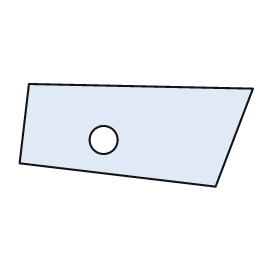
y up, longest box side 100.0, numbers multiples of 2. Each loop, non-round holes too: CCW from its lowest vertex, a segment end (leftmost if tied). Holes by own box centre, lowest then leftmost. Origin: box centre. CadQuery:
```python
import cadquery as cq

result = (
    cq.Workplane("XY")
    .moveTo(34.0, -22.0)
    .lineTo(50.0, 20.0)
    .lineTo(-46.0, 22.0)
    .lineTo(-50.0, -12.0)
    .close()
    .moveTo(-14.0, -2.0)
    .circle(6.0)
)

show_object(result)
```